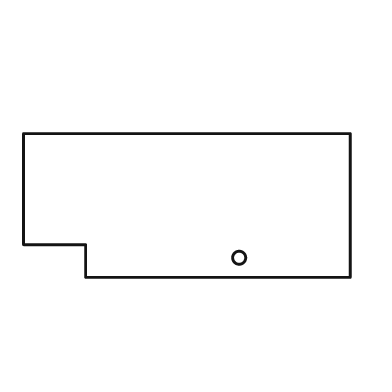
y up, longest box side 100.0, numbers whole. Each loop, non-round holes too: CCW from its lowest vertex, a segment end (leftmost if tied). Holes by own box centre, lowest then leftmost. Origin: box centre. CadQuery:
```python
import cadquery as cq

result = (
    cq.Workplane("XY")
    .moveTo(-31.0, -22.0)
    .lineTo(50.0, -22.0)
    .lineTo(50.0, 22.0)
    .lineTo(-50.0, 22.0)
    .lineTo(-50.0, -12.0)
    .lineTo(-31.0, -12.0)
    .close()
    .moveTo(16.0, -16.0)
    .circle(2.0)
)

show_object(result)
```